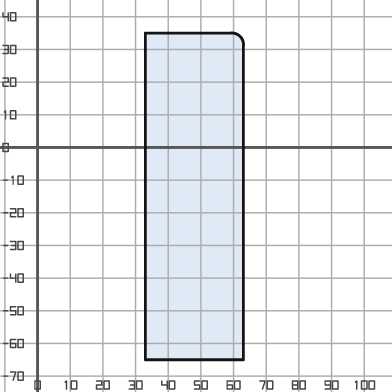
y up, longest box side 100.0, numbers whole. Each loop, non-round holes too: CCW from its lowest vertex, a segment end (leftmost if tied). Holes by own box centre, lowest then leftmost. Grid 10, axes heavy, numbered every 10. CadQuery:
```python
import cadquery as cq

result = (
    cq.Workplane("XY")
    .moveTo(33.0, -65.0)
    .lineTo(63.0, -65.0)
    .lineTo(63.0, 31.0)
    .threePointArc((62.0, 34.0), (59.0, 35.0))
    .lineTo(33.0, 35.0)
    .close()
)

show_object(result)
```